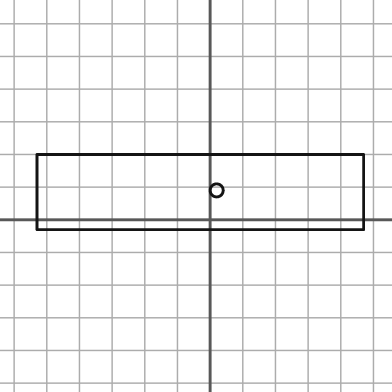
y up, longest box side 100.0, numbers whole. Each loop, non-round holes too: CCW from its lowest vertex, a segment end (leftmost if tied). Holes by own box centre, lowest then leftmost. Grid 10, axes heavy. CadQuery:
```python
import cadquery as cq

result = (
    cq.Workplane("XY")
    .moveTo(-53.0, -3.0)
    .lineTo(47.0, -3.0)
    .lineTo(47.0, 20.0)
    .lineTo(-53.0, 20.0)
    .close()
    .moveTo(2.0, 9.0)
    .circle(2.0)
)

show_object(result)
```